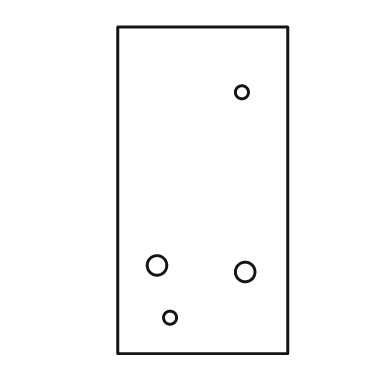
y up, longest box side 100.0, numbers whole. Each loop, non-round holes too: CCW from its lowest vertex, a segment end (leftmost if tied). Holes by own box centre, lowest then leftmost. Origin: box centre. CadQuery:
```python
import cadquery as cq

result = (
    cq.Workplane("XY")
    .moveTo(-26.0, -50.0)
    .lineTo(26.0, -50.0)
    .lineTo(26.0, 50.0)
    .lineTo(-26.0, 50.0)
    .close()
    .moveTo(-10.0, -39.0)
    .circle(2.0)
    .moveTo(13.0, -25.0)
    .circle(3.0)
    .moveTo(-14.0, -23.0)
    .circle(3.0)
    .moveTo(12.0, 30.0)
    .circle(2.0)
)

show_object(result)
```